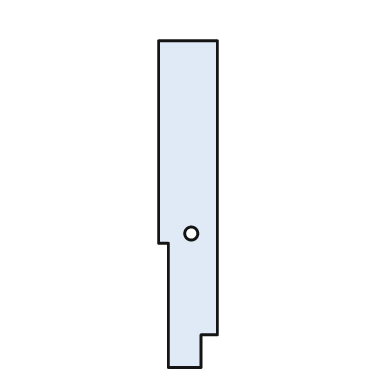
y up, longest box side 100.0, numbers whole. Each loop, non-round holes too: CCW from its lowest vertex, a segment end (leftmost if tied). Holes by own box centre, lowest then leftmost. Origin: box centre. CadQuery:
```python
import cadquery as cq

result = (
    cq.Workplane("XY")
    .moveTo(-6.0, -50.0)
    .lineTo(4.0, -50.0)
    .lineTo(4.0, -40.0)
    .lineTo(9.0, -40.0)
    .lineTo(9.0, 50.0)
    .lineTo(-9.0, 50.0)
    .lineTo(-9.0, -12.0)
    .lineTo(-6.0, -12.0)
    .close()
    .moveTo(1.0, -9.0)
    .circle(2.0)
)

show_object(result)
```